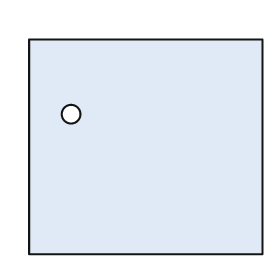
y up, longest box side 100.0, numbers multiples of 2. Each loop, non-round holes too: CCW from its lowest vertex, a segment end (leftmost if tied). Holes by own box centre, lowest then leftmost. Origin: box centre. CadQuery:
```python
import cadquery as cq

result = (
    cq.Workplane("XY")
    .moveTo(-50.0, -46.0)
    .lineTo(50.0, -46.0)
    .lineTo(50.0, 46.0)
    .lineTo(-50.0, 46.0)
    .close()
    .moveTo(-32.0, 14.0)
    .circle(4.0)
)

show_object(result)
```